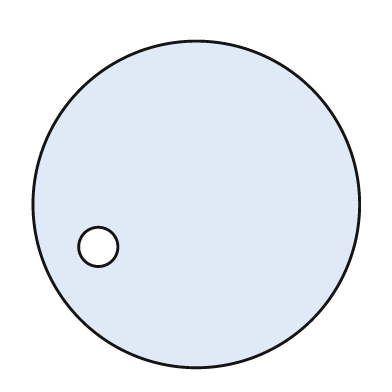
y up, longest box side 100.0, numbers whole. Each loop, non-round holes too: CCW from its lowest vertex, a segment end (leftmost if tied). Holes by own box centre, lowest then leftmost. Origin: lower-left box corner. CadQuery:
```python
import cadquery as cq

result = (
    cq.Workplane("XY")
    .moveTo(50.0, 50.0)
    .circle(50.0)
    .moveTo(20.0, 37.0)
    .circle(6.0)
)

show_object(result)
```